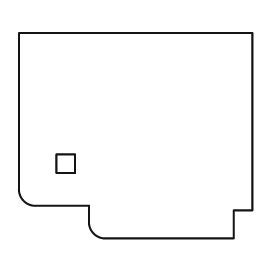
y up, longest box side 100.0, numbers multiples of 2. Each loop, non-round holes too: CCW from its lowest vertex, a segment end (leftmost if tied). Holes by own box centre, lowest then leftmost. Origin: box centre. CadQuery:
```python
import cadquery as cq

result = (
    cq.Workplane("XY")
    .moveTo(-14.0, -44.0)
    .lineTo(42.0, -44.0)
    .lineTo(42.0, -32.0)
    .lineTo(50.0, -32.0)
    .lineTo(50.0, 44.0)
    .lineTo(-50.0, 44.0)
    .lineTo(-50.0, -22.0)
    .threePointArc((-48.0, -28.0), (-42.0, -30.0))
    .lineTo(-20.0, -30.0)
    .lineTo(-20.0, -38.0)
    .threePointArc((-18.0, -42.0), (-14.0, -44.0))
    .close()
    .moveTo(-34.0, -16.0)
    .lineTo(-26.0, -16.0)
    .lineTo(-26.0, -8.0)
    .lineTo(-34.0, -8.0)
    .close()
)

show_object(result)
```